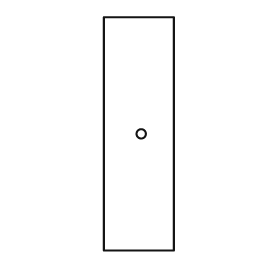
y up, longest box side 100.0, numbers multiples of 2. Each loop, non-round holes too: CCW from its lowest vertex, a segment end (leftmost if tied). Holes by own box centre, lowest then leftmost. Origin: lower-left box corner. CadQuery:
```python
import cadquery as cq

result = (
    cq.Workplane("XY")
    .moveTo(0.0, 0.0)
    .lineTo(30.0, 0.0)
    .lineTo(30.0, 100.0)
    .lineTo(0.0, 100.0)
    .close()
    .moveTo(16.0, 50.0)
    .circle(2.0)
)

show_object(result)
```